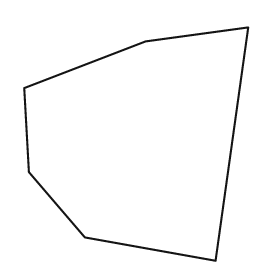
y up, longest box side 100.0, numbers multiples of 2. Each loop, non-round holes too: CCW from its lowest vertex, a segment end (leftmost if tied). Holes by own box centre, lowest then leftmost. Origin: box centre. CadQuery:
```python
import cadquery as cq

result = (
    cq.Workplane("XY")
    .moveTo(34.0, -50.0)
    .lineTo(48.0, 50.0)
    .lineTo(4.0, 44.0)
    .lineTo(-48.0, 24.0)
    .lineTo(-46.0, -12.0)
    .lineTo(-22.0, -40.0)
    .close()
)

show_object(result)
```